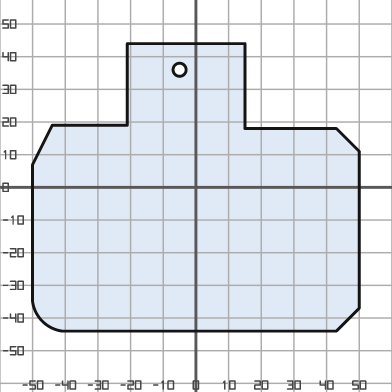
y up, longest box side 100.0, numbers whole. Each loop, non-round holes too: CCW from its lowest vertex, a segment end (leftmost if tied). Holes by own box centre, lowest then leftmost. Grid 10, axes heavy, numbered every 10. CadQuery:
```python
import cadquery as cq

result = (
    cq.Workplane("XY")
    .moveTo(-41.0, -44.0)
    .lineTo(43.0, -44.0)
    .lineTo(50.0, -37.0)
    .lineTo(50.0, 11.0)
    .lineTo(43.0, 18.0)
    .lineTo(15.0, 18.0)
    .lineTo(15.0, 44.0)
    .lineTo(-21.0, 44.0)
    .lineTo(-21.0, 19.0)
    .lineTo(-44.0, 19.0)
    .lineTo(-50.0, 7.0)
    .lineTo(-50.0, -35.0)
    .threePointArc((-47.0, -41.0), (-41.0, -44.0))
    .close()
    .moveTo(-5.0, 36.0)
    .circle(2.0)
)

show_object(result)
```